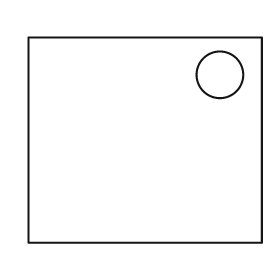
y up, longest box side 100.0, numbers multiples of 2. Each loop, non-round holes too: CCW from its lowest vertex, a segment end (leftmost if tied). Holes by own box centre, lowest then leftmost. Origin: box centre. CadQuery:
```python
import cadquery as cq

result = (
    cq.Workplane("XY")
    .moveTo(-50.0, -44.0)
    .lineTo(50.0, -44.0)
    .lineTo(50.0, 44.0)
    .lineTo(-50.0, 44.0)
    .close()
    .moveTo(32.0, 28.0)
    .circle(10.0)
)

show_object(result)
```